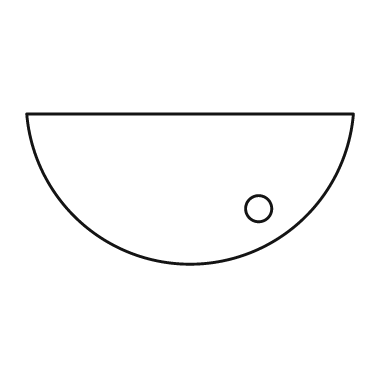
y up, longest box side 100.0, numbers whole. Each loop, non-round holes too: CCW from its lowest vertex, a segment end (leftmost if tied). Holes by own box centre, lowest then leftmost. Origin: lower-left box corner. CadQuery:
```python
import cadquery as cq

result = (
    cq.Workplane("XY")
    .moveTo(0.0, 46.0)
    .threePointArc((50.0, 0.0), (100.0, 46.0))
    .close()
    .moveTo(71.0, 17.0)
    .circle(4.0)
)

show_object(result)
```